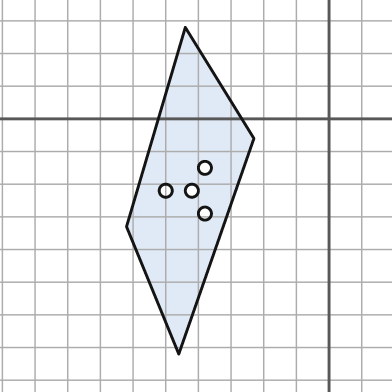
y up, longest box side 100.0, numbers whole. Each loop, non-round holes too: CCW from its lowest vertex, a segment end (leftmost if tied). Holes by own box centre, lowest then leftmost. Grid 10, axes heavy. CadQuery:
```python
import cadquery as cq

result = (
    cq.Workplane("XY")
    .moveTo(-46.0, -72.0)
    .lineTo(-23.0, -6.0)
    .lineTo(-44.0, 28.0)
    .lineTo(-62.0, -33.0)
    .close()
    .moveTo(-38.0, -29.0)
    .circle(2.0)
    .moveTo(-50.0, -22.0)
    .circle(2.0)
    .moveTo(-42.0, -22.0)
    .circle(2.0)
    .moveTo(-38.0, -15.0)
    .circle(2.0)
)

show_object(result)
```